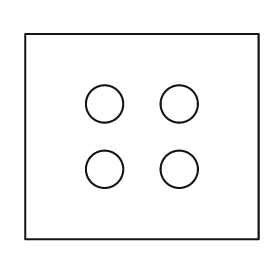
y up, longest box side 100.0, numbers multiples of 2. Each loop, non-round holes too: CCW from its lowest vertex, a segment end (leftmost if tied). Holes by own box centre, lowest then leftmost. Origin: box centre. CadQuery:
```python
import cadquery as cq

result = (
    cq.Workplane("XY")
    .moveTo(-50.0, -44.0)
    .lineTo(50.0, -44.0)
    .lineTo(50.0, 44.0)
    .lineTo(-50.0, 44.0)
    .close()
    .moveTo(-16.0, -14.0)
    .circle(8.0)
    .moveTo(16.0, -14.0)
    .circle(8.0)
    .moveTo(-16.0, 14.0)
    .circle(8.0)
    .moveTo(16.0, 14.0)
    .circle(8.0)
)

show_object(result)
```